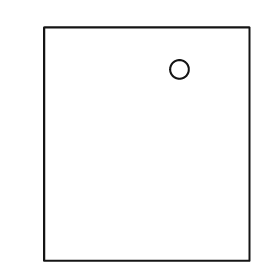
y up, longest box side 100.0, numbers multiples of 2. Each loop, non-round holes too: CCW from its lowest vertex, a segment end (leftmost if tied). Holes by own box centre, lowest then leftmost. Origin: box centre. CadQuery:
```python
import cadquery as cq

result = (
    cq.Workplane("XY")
    .moveTo(-44.0, -50.0)
    .lineTo(44.0, -50.0)
    .lineTo(44.0, 50.0)
    .lineTo(-44.0, 50.0)
    .close()
    .moveTo(14.0, 32.0)
    .circle(4.0)
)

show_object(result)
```